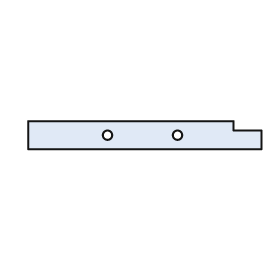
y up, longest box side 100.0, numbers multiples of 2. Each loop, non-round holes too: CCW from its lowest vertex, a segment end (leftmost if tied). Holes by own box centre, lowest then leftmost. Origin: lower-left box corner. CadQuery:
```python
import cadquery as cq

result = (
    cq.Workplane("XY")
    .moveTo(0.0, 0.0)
    .lineTo(100.0, 0.0)
    .lineTo(100.0, 8.0)
    .lineTo(88.0, 8.0)
    .lineTo(88.0, 12.0)
    .lineTo(0.0, 12.0)
    .close()
    .moveTo(34.0, 6.0)
    .circle(2.0)
    .moveTo(64.0, 6.0)
    .circle(2.0)
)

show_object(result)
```